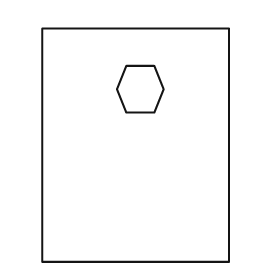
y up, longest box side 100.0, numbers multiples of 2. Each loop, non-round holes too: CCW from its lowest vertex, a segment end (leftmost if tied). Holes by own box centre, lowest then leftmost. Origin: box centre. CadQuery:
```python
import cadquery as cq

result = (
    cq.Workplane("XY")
    .moveTo(-40.0, -50.0)
    .lineTo(40.0, -50.0)
    .lineTo(40.0, 50.0)
    .lineTo(-40.0, 50.0)
    .close()
    .moveTo(-4.0, 14.0)
    .lineTo(8.0, 14.0)
    .lineTo(12.0, 24.0)
    .lineTo(8.0, 34.0)
    .lineTo(-4.0, 34.0)
    .lineTo(-8.0, 24.0)
    .close()
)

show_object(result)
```